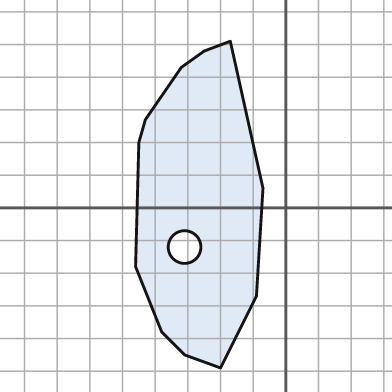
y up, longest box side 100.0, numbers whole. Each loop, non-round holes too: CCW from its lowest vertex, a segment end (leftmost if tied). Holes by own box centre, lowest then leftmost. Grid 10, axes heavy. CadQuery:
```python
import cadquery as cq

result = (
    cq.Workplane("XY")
    .moveTo(-20.0, -49.0)
    .lineTo(-9.0, -27.0)
    .lineTo(-7.0, 6.0)
    .lineTo(-17.0, 51.0)
    .lineTo(-25.0, 48.0)
    .lineTo(-32.0, 43.0)
    .lineTo(-43.0, 27.0)
    .lineTo(-45.0, 20.0)
    .lineTo(-46.0, -18.0)
    .lineTo(-38.0, -38.0)
    .lineTo(-31.0, -45.0)
    .close()
    .moveTo(-31.0, -12.0)
    .circle(5.0)
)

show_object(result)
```